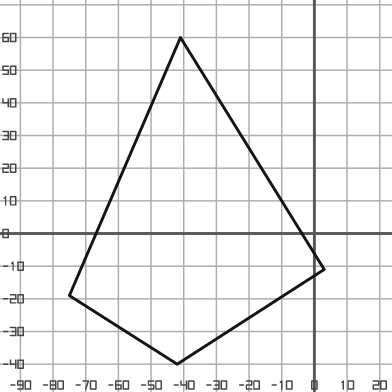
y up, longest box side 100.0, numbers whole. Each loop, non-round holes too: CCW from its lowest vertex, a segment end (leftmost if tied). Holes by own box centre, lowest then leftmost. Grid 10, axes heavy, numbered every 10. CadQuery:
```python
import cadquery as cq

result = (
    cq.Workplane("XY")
    .moveTo(-42.0, -40.0)
    .lineTo(3.0, -11.0)
    .lineTo(-41.0, 60.0)
    .lineTo(-75.0, -19.0)
    .close()
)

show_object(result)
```